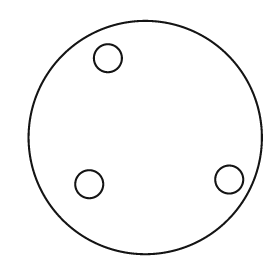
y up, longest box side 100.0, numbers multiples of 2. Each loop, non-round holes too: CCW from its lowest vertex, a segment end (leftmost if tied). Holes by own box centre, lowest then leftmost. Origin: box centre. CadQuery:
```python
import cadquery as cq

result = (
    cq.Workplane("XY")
    .moveTo(0.0, 0.0)
    .circle(50.0)
    .moveTo(-24.0, -20.0)
    .circle(6.0)
    .moveTo(36.0, -18.0)
    .circle(6.0)
    .moveTo(-16.0, 34.0)
    .circle(6.0)
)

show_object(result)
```